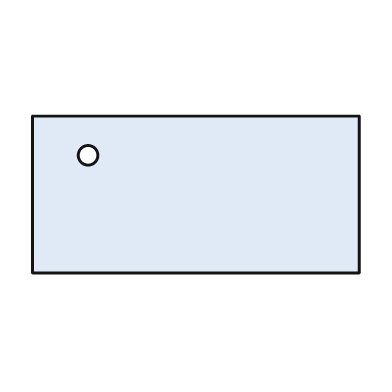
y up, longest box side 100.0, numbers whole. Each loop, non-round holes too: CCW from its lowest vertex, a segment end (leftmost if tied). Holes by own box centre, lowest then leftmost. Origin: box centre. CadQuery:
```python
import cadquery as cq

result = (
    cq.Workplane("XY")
    .moveTo(-50.0, -24.0)
    .lineTo(50.0, -24.0)
    .lineTo(50.0, 24.0)
    .lineTo(-50.0, 24.0)
    .close()
    .moveTo(-33.0, 12.0)
    .circle(3.0)
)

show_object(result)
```